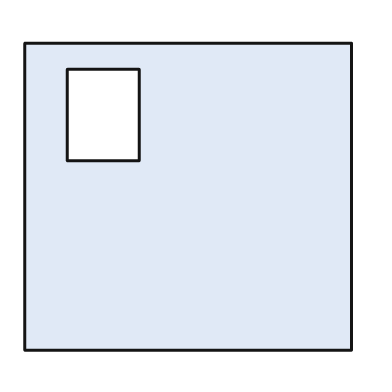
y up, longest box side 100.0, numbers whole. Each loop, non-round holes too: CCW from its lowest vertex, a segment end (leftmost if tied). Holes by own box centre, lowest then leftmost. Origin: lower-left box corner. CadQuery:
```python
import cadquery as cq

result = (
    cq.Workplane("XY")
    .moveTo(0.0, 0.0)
    .lineTo(100.0, 0.0)
    .lineTo(100.0, 94.0)
    .lineTo(0.0, 94.0)
    .close()
    .moveTo(13.0, 58.0)
    .lineTo(35.0, 58.0)
    .lineTo(35.0, 86.0)
    .lineTo(13.0, 86.0)
    .close()
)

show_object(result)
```